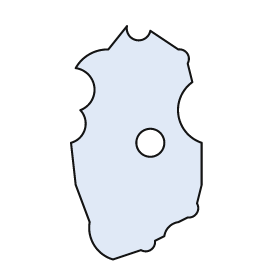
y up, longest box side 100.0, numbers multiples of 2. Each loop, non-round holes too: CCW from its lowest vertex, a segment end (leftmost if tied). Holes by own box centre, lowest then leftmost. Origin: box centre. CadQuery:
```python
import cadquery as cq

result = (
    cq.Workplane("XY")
    .moveTo(-10.0, -50.0)
    .lineTo(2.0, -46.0)
    .threePointArc((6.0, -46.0), (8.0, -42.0))
    .lineTo(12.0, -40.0)
    .threePointArc((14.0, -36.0), (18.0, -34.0))
    .lineTo(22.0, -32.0)
    .threePointArc((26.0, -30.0), (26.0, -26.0))
    .lineTo(28.0, -18.0)
    .lineTo(28.0, 0.0)
    .threePointArc((18.0, 12.0), (24.0, 26.0))
    .lineTo(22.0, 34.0)
    .threePointArc((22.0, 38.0), (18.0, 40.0))
    .lineTo(6.0, 48.0)
    .threePointArc((0.0, 44.0), (-4.0, 50.0))
    .lineTo(-12.0, 40.0)
    .threePointArc((-20.0, 38.0), (-26.0, 32.0))
    .threePointArc((-18.0, 24.0), (-24.0, 14.0))
    .threePointArc((-22.0, 6.0), (-28.0, 0.0))
    .lineTo(-26.0, -18.0)
    .lineTo(-20.0, -34.0)
    .threePointArc((-18.0, -44.0), (-10.0, -50.0))
    .close()
    .moveTo(6.0, 0.0)
    .circle(6.0)
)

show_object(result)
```